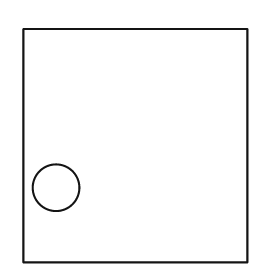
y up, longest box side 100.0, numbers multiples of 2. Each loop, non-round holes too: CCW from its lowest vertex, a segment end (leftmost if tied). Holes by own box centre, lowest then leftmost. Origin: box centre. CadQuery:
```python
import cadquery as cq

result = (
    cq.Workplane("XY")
    .moveTo(-48.0, -50.0)
    .lineTo(48.0, -50.0)
    .lineTo(48.0, 50.0)
    .lineTo(-48.0, 50.0)
    .close()
    .moveTo(-34.0, -18.0)
    .circle(10.0)
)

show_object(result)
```